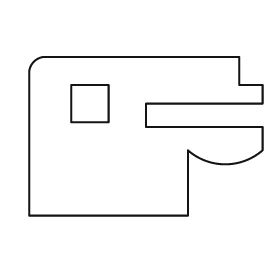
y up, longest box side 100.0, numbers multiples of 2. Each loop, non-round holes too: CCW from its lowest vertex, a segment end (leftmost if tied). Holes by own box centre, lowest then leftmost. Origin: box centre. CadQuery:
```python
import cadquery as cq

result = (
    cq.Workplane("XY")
    .moveTo(-50.0, -34.0)
    .lineTo(18.0, -34.0)
    .lineTo(18.0, -6.0)
    .threePointArc((34.0, -12.0), (50.0, -6.0))
    .lineTo(50.0, 4.0)
    .lineTo(0.0, 4.0)
    .lineTo(0.0, 14.0)
    .lineTo(50.0, 14.0)
    .lineTo(50.0, 22.0)
    .lineTo(40.0, 22.0)
    .lineTo(40.0, 34.0)
    .lineTo(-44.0, 34.0)
    .threePointArc((-48.0, 32.0), (-50.0, 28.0))
    .close()
    .moveTo(-32.0, 6.0)
    .lineTo(-16.0, 6.0)
    .lineTo(-16.0, 22.0)
    .lineTo(-32.0, 22.0)
    .close()
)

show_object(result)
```